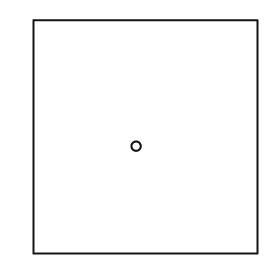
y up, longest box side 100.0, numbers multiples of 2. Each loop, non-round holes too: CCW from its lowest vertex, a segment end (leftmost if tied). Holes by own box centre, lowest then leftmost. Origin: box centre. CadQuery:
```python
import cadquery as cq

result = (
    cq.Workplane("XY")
    .moveTo(-48.0, -50.0)
    .lineTo(48.0, -50.0)
    .lineTo(48.0, 50.0)
    .lineTo(-48.0, 50.0)
    .close()
    .moveTo(-4.0, -4.0)
    .circle(2.0)
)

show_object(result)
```